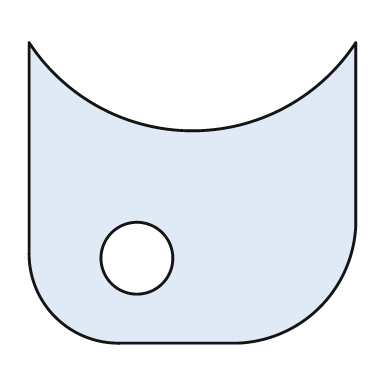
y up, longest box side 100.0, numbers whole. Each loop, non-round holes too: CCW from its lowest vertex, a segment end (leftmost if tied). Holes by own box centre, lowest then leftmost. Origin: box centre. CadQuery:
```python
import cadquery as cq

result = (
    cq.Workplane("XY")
    .moveTo(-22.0, -46.0)
    .lineTo(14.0, -46.0)
    .threePointArc((39.0, -35.0), (50.0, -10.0))
    .lineTo(50.0, 46.0)
    .threePointArc((0.0, 19.0), (-50.0, 46.0))
    .lineTo(-50.0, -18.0)
    .threePointArc((-42.0, -38.0), (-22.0, -46.0))
    .close()
    .moveTo(-17.0, -20.0)
    .circle(11.0)
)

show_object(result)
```